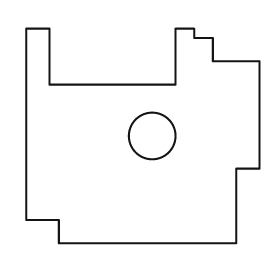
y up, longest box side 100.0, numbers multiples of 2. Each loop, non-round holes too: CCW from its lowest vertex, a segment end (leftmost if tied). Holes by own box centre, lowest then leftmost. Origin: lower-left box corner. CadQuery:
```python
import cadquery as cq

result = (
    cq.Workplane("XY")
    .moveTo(14.0, 0.0)
    .lineTo(90.0, 0.0)
    .lineTo(90.0, 32.0)
    .lineTo(100.0, 32.0)
    .lineTo(100.0, 78.0)
    .lineTo(80.0, 78.0)
    .lineTo(80.0, 88.0)
    .lineTo(72.0, 88.0)
    .lineTo(72.0, 92.0)
    .lineTo(64.0, 92.0)
    .lineTo(64.0, 68.0)
    .lineTo(10.0, 68.0)
    .lineTo(10.0, 92.0)
    .lineTo(0.0, 92.0)
    .lineTo(0.0, 10.0)
    .lineTo(14.0, 10.0)
    .close()
    .moveTo(54.0, 46.0)
    .circle(10.0)
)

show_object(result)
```